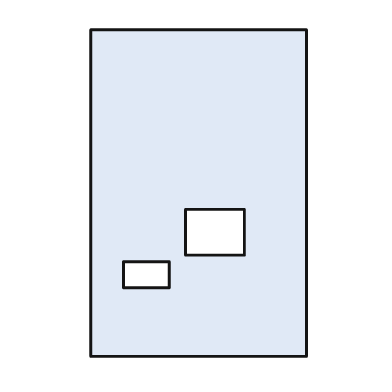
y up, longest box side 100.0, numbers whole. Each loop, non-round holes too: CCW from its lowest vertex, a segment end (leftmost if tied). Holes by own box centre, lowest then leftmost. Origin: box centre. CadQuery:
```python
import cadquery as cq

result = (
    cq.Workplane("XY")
    .moveTo(-33.0, -50.0)
    .lineTo(33.0, -50.0)
    .lineTo(33.0, 50.0)
    .lineTo(-33.0, 50.0)
    .close()
    .moveTo(-23.0, -29.0)
    .lineTo(-9.0, -29.0)
    .lineTo(-9.0, -21.0)
    .lineTo(-23.0, -21.0)
    .close()
    .moveTo(-4.0, -19.0)
    .lineTo(14.0, -19.0)
    .lineTo(14.0, -5.0)
    .lineTo(-4.0, -5.0)
    .close()
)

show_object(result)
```